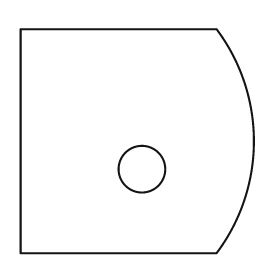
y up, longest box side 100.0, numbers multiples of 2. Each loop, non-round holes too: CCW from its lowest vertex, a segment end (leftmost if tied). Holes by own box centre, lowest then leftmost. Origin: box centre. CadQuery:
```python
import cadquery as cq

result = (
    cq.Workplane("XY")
    .moveTo(-50.0, -48.0)
    .lineTo(34.0, -48.0)
    .threePointArc((50.0, 0.0), (34.0, 48.0))
    .lineTo(-50.0, 48.0)
    .close()
    .moveTo(2.0, -12.0)
    .circle(10.0)
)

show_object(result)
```